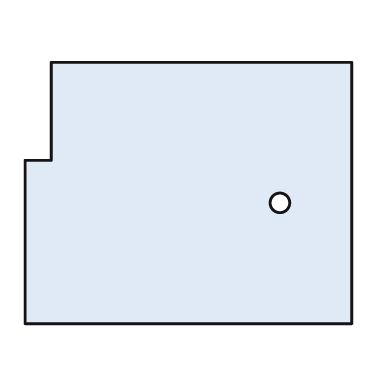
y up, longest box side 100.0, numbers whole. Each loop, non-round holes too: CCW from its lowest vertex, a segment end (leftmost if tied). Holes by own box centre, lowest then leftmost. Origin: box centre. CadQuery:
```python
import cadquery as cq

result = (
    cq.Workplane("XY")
    .moveTo(-50.0, -40.0)
    .lineTo(50.0, -40.0)
    .lineTo(50.0, 40.0)
    .lineTo(-42.0, 40.0)
    .lineTo(-42.0, 10.0)
    .lineTo(-50.0, 10.0)
    .close()
    .moveTo(28.0, -3.0)
    .circle(3.0)
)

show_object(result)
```